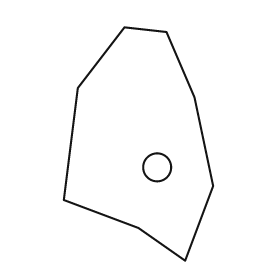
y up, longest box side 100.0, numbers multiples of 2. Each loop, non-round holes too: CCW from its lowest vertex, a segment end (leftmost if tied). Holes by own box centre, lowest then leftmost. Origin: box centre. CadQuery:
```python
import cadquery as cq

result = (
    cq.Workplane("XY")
    .moveTo(20.0, -50.0)
    .lineTo(32.0, -18.0)
    .lineTo(24.0, 20.0)
    .lineTo(12.0, 48.0)
    .lineTo(-6.0, 50.0)
    .lineTo(-26.0, 24.0)
    .lineTo(-32.0, -24.0)
    .lineTo(0.0, -36.0)
    .close()
    .moveTo(8.0, -10.0)
    .circle(6.0)
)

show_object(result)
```